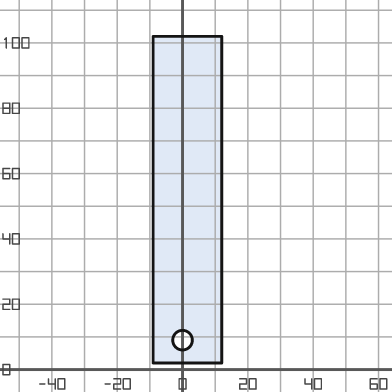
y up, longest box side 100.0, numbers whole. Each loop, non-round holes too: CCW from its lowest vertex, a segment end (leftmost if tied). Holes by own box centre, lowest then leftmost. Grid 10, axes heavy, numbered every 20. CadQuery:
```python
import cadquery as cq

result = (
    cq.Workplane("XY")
    .moveTo(-9.0, 2.0)
    .lineTo(12.0, 2.0)
    .lineTo(12.0, 102.0)
    .lineTo(-9.0, 102.0)
    .close()
    .moveTo(0.0, 9.0)
    .circle(3.0)
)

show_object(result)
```